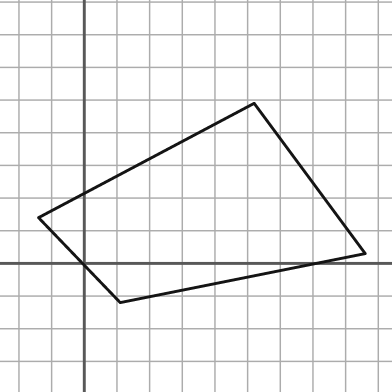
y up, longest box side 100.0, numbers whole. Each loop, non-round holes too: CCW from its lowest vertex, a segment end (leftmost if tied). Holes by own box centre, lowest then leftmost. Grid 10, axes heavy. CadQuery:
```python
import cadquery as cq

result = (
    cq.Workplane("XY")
    .moveTo(11.0, -12.0)
    .lineTo(86.0, 3.0)
    .lineTo(52.0, 49.0)
    .lineTo(-14.0, 14.0)
    .close()
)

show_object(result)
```